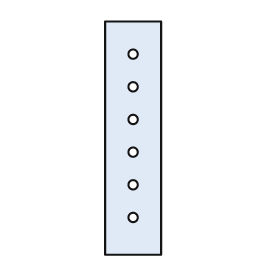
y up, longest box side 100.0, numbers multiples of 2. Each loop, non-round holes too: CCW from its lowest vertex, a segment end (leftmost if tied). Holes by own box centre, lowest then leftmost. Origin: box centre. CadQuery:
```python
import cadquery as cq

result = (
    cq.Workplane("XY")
    .moveTo(-12.0, -50.0)
    .lineTo(12.0, -50.0)
    .lineTo(12.0, 50.0)
    .lineTo(-12.0, 50.0)
    .close()
    .moveTo(0.0, -34.0)
    .circle(2.0)
    .moveTo(0.0, -20.0)
    .circle(2.0)
    .moveTo(0.0, -6.0)
    .circle(2.0)
    .moveTo(0.0, 8.0)
    .circle(2.0)
    .moveTo(0.0, 22.0)
    .circle(2.0)
    .moveTo(0.0, 36.0)
    .circle(2.0)
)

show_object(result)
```